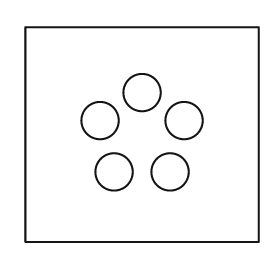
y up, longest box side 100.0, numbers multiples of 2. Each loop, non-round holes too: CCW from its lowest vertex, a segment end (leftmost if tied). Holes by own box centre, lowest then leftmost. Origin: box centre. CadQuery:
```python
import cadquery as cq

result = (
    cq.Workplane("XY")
    .moveTo(-50.0, -46.0)
    .lineTo(50.0, -46.0)
    .lineTo(50.0, 46.0)
    .lineTo(-50.0, 46.0)
    .close()
    .moveTo(-12.0, -16.0)
    .circle(8.0)
    .moveTo(12.0, -16.0)
    .circle(8.0)
    .moveTo(-18.0, 6.0)
    .circle(8.0)
    .moveTo(18.0, 6.0)
    .circle(8.0)
    .moveTo(0.0, 18.0)
    .circle(8.0)
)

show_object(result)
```